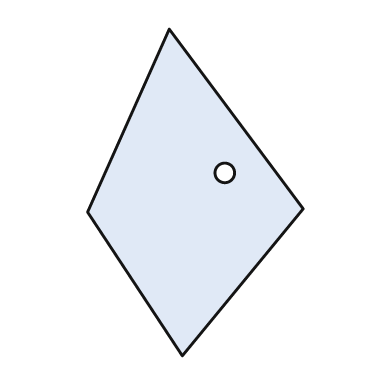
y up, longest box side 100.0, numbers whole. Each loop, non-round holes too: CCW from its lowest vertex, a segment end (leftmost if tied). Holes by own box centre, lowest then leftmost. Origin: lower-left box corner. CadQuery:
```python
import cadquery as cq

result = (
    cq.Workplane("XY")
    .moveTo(29.0, 0.0)
    .lineTo(66.0, 45.0)
    .lineTo(25.0, 100.0)
    .lineTo(0.0, 44.0)
    .close()
    .moveTo(42.0, 56.0)
    .circle(3.0)
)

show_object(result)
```